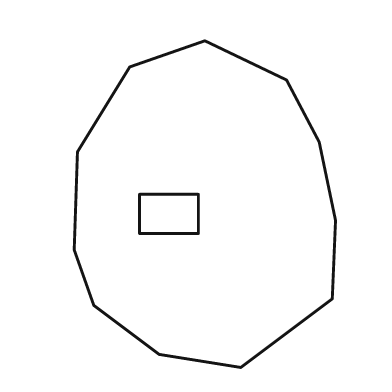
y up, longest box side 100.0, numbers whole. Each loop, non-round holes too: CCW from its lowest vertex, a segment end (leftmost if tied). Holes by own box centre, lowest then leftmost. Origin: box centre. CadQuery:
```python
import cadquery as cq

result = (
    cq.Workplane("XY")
    .moveTo(11.0, -50.0)
    .lineTo(39.0, -29.0)
    .lineTo(40.0, -5.0)
    .lineTo(35.0, 19.0)
    .lineTo(25.0, 38.0)
    .lineTo(0.0, 50.0)
    .lineTo(-23.0, 42.0)
    .lineTo(-39.0, 16.0)
    .lineTo(-40.0, -14.0)
    .lineTo(-34.0, -31.0)
    .lineTo(-14.0, -46.0)
    .close()
    .moveTo(-20.0, -9.0)
    .lineTo(-2.0, -9.0)
    .lineTo(-2.0, 3.0)
    .lineTo(-20.0, 3.0)
    .close()
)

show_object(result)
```